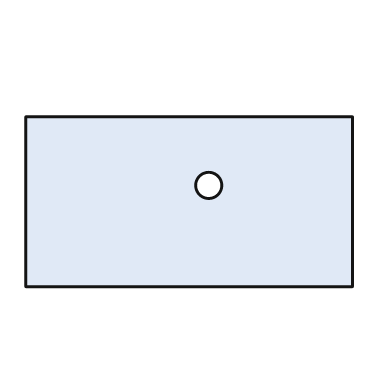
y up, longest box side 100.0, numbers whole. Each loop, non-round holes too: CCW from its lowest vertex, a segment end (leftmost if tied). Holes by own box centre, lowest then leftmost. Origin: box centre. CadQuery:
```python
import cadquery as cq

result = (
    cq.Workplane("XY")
    .moveTo(-50.0, -26.0)
    .lineTo(50.0, -26.0)
    .lineTo(50.0, 26.0)
    .lineTo(-50.0, 26.0)
    .close()
    .moveTo(6.0, 5.0)
    .circle(4.0)
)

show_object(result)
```